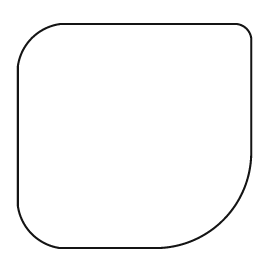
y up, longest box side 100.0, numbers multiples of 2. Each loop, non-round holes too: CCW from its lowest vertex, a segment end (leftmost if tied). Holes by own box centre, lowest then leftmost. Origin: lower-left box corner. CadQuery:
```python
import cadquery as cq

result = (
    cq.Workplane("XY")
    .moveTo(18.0, 0.0)
    .lineTo(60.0, 0.0)
    .threePointArc((88.0, 12.0), (100.0, 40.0))
    .lineTo(100.0, 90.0)
    .threePointArc((98.0, 94.0), (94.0, 96.0))
    .lineTo(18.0, 96.0)
    .threePointArc((6.0, 90.0), (0.0, 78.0))
    .lineTo(0.0, 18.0)
    .threePointArc((6.0, 6.0), (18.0, 0.0))
    .close()
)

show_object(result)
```